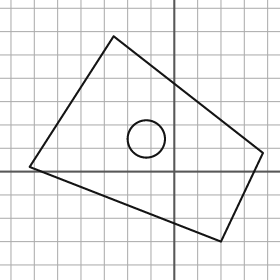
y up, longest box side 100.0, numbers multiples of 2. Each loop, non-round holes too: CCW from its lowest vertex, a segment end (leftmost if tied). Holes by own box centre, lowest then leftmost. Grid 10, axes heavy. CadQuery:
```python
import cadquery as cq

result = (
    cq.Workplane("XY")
    .moveTo(20.0, -30.0)
    .lineTo(38.0, 8.0)
    .lineTo(-26.0, 58.0)
    .lineTo(-62.0, 2.0)
    .close()
    .moveTo(-12.0, 14.0)
    .circle(8.0)
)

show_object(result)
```